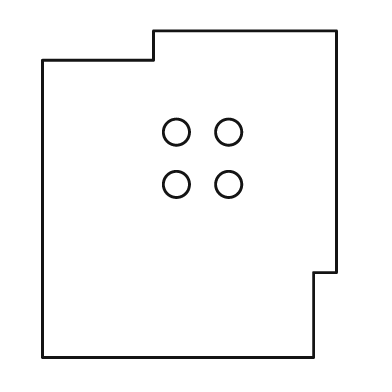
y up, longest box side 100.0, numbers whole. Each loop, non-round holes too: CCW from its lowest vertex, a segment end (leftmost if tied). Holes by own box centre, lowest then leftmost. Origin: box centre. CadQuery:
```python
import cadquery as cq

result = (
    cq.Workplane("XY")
    .moveTo(-45.0, -50.0)
    .lineTo(38.0, -50.0)
    .lineTo(38.0, -24.0)
    .lineTo(45.0, -24.0)
    .lineTo(45.0, 50.0)
    .lineTo(-11.0, 50.0)
    .lineTo(-11.0, 41.0)
    .lineTo(-45.0, 41.0)
    .close()
    .moveTo(-4.0, 3.0)
    .circle(4.0)
    .moveTo(12.0, 3.0)
    .circle(4.0)
    .moveTo(-4.0, 19.0)
    .circle(4.0)
    .moveTo(12.0, 19.0)
    .circle(4.0)
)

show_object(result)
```